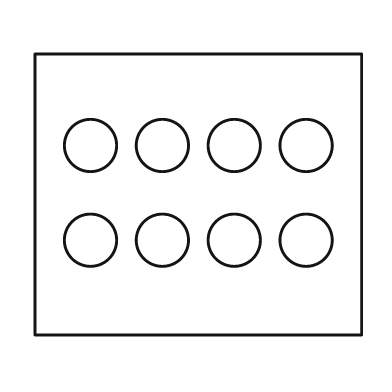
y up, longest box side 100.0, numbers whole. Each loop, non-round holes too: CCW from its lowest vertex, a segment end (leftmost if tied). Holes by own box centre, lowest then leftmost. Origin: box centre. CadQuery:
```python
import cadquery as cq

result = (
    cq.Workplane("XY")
    .moveTo(-50.0, -43.0)
    .lineTo(50.0, -43.0)
    .lineTo(50.0, 43.0)
    .lineTo(-50.0, 43.0)
    .close()
    .moveTo(-33.0, -14.0)
    .circle(8.0)
    .moveTo(-11.0, -14.0)
    .circle(8.0)
    .moveTo(11.0, -14.0)
    .circle(8.0)
    .moveTo(33.0, -14.0)
    .circle(8.0)
    .moveTo(-33.0, 15.0)
    .circle(8.0)
    .moveTo(-11.0, 15.0)
    .circle(8.0)
    .moveTo(11.0, 15.0)
    .circle(8.0)
    .moveTo(33.0, 15.0)
    .circle(8.0)
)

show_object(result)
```